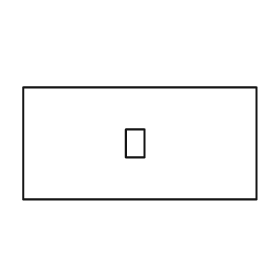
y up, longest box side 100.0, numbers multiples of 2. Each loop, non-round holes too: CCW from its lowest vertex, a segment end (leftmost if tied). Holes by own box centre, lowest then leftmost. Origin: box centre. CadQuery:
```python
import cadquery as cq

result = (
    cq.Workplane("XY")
    .moveTo(-50.0, -24.0)
    .lineTo(50.0, -24.0)
    .lineTo(50.0, 24.0)
    .lineTo(-50.0, 24.0)
    .close()
    .moveTo(-6.0, -6.0)
    .lineTo(2.0, -6.0)
    .lineTo(2.0, 6.0)
    .lineTo(-6.0, 6.0)
    .close()
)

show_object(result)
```